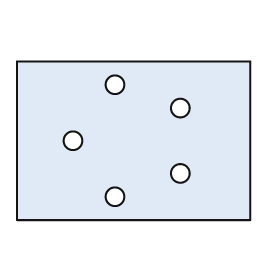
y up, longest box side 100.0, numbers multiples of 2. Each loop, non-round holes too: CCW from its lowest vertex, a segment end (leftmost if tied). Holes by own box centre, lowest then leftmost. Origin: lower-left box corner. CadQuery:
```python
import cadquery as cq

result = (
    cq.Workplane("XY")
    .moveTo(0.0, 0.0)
    .lineTo(100.0, 0.0)
    .lineTo(100.0, 68.0)
    .lineTo(0.0, 68.0)
    .close()
    .moveTo(42.0, 10.0)
    .circle(4.0)
    .moveTo(70.0, 20.0)
    .circle(4.0)
    .moveTo(24.0, 34.0)
    .circle(4.0)
    .moveTo(70.0, 48.0)
    .circle(4.0)
    .moveTo(42.0, 58.0)
    .circle(4.0)
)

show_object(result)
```